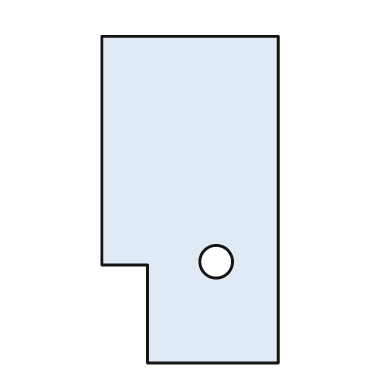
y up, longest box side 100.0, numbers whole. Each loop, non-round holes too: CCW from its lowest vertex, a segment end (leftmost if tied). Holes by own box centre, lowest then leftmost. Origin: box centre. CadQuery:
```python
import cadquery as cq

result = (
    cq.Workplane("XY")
    .moveTo(-13.0, -50.0)
    .lineTo(27.0, -50.0)
    .lineTo(27.0, 50.0)
    .lineTo(-27.0, 50.0)
    .lineTo(-27.0, -20.0)
    .lineTo(-13.0, -20.0)
    .close()
    .moveTo(8.0, -19.0)
    .circle(5.0)
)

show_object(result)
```